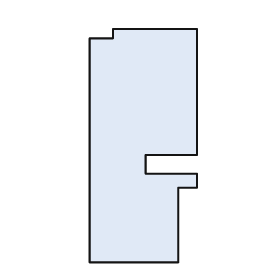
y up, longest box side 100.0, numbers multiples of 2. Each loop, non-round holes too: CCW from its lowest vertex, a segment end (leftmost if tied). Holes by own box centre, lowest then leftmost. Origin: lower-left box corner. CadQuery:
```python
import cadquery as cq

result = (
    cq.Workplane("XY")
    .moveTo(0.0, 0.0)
    .lineTo(38.0, 0.0)
    .lineTo(38.0, 32.0)
    .lineTo(46.0, 32.0)
    .lineTo(46.0, 38.0)
    .lineTo(24.0, 38.0)
    .lineTo(24.0, 46.0)
    .lineTo(46.0, 46.0)
    .lineTo(46.0, 100.0)
    .lineTo(10.0, 100.0)
    .lineTo(10.0, 96.0)
    .lineTo(0.0, 96.0)
    .close()
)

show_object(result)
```